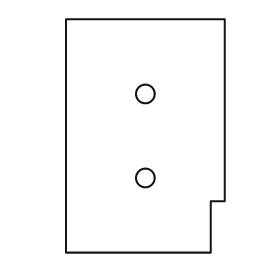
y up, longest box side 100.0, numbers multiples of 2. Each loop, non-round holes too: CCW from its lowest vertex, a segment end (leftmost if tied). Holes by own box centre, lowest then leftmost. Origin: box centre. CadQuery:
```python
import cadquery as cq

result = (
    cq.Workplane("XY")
    .moveTo(-34.0, -50.0)
    .lineTo(28.0, -50.0)
    .lineTo(28.0, -28.0)
    .lineTo(34.0, -28.0)
    .lineTo(34.0, 50.0)
    .lineTo(-34.0, 50.0)
    .close()
    .moveTo(0.0, -18.0)
    .circle(4.0)
    .moveTo(0.0, 18.0)
    .circle(4.0)
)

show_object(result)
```